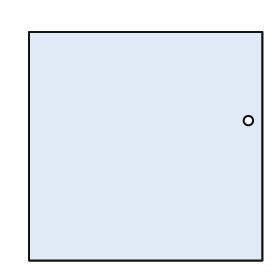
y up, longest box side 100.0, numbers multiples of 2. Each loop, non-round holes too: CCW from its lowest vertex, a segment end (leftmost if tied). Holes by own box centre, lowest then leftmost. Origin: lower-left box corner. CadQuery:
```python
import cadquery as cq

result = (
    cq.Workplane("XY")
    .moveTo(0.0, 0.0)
    .lineTo(100.0, 0.0)
    .lineTo(100.0, 98.0)
    .lineTo(0.0, 98.0)
    .close()
    .moveTo(94.0, 60.0)
    .circle(2.0)
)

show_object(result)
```